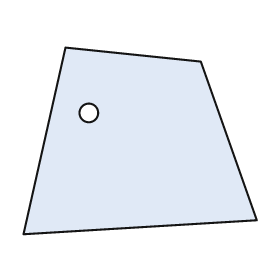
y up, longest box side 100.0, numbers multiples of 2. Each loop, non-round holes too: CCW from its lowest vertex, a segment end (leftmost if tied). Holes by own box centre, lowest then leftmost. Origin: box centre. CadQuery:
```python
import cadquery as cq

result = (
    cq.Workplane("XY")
    .moveTo(-50.0, -40.0)
    .lineTo(50.0, -34.0)
    .lineTo(26.0, 34.0)
    .lineTo(-32.0, 40.0)
    .close()
    .moveTo(-22.0, 12.0)
    .circle(4.0)
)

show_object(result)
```